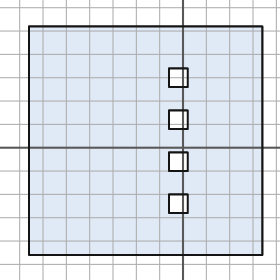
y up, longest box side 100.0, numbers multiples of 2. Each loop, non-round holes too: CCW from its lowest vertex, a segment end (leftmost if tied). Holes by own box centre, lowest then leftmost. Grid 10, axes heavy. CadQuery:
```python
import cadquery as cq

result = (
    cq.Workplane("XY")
    .moveTo(-66.0, -46.0)
    .lineTo(34.0, -46.0)
    .lineTo(34.0, 52.0)
    .lineTo(-66.0, 52.0)
    .close()
    .moveTo(-6.0, -28.0)
    .lineTo(2.0, -28.0)
    .lineTo(2.0, -20.0)
    .lineTo(-6.0, -20.0)
    .close()
    .moveTo(-6.0, -10.0)
    .lineTo(2.0, -10.0)
    .lineTo(2.0, -2.0)
    .lineTo(-6.0, -2.0)
    .close()
    .moveTo(-6.0, 8.0)
    .lineTo(2.0, 8.0)
    .lineTo(2.0, 16.0)
    .lineTo(-6.0, 16.0)
    .close()
    .moveTo(-6.0, 26.0)
    .lineTo(2.0, 26.0)
    .lineTo(2.0, 34.0)
    .lineTo(-6.0, 34.0)
    .close()
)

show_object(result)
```